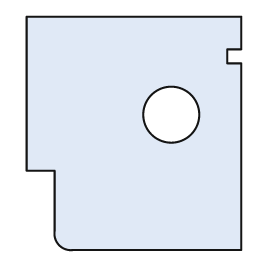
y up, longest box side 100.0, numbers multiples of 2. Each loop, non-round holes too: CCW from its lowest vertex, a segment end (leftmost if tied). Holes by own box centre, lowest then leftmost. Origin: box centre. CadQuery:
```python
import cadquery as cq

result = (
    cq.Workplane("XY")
    .moveTo(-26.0, -50.0)
    .lineTo(46.0, -50.0)
    .lineTo(46.0, 30.0)
    .lineTo(40.0, 30.0)
    .lineTo(40.0, 36.0)
    .lineTo(46.0, 36.0)
    .lineTo(46.0, 50.0)
    .lineTo(-46.0, 50.0)
    .lineTo(-46.0, -16.0)
    .lineTo(-34.0, -16.0)
    .lineTo(-34.0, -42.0)
    .threePointArc((-32.0, -48.0), (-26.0, -50.0))
    .close()
    .moveTo(16.0, 8.0)
    .circle(12.0)
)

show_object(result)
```